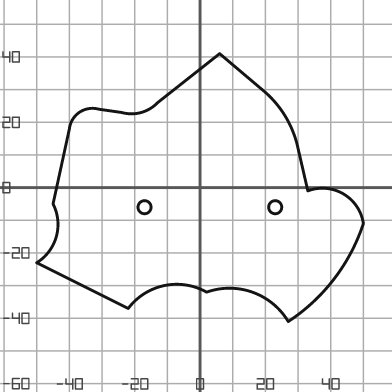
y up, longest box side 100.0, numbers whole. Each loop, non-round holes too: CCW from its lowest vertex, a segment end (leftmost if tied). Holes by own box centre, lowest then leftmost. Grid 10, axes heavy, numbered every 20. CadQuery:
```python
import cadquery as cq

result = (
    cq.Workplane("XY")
    .moveTo(27.0, -41.0)
    .threePointArc((41.0, -28.0), (50.0, -11.0))
    .threePointArc((44.0, -2.0), (33.0, -1.0))
    .lineTo(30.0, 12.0)
    .threePointArc((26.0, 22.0), (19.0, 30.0))
    .lineTo(6.0, 41.0)
    .lineTo(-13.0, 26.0)
    .threePointArc((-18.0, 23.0), (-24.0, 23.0))
    .lineTo(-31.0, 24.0)
    .threePointArc((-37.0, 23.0), (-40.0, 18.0))
    .lineTo(-45.0, -5.0)
    .threePointArc((-44.0, -15.0), (-50.0, -23.0))
    .lineTo(-22.0, -37.0)
    .threePointArc((-11.0, -30.0), (2.0, -32.0))
    .threePointArc((16.0, -32.0), (27.0, -41.0))
    .close()
    .moveTo(-17.0, -6.0)
    .circle(2.0)
    .moveTo(23.0, -6.0)
    .circle(2.0)
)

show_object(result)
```